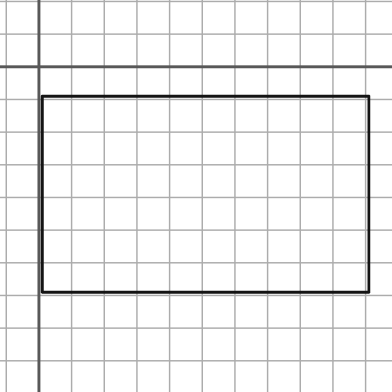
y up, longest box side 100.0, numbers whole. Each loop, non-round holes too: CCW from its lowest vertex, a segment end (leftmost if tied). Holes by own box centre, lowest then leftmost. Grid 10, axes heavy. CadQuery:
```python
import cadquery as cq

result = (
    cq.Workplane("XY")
    .moveTo(1.0, -69.0)
    .lineTo(101.0, -69.0)
    .lineTo(101.0, -9.0)
    .lineTo(1.0, -9.0)
    .close()
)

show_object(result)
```